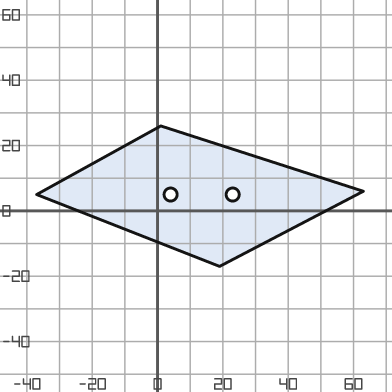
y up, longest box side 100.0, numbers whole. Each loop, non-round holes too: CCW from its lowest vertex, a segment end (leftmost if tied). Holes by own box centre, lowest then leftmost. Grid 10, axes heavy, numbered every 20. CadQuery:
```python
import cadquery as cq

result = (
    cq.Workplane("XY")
    .moveTo(19.0, -17.0)
    .lineTo(63.0, 6.0)
    .lineTo(1.0, 26.0)
    .lineTo(-37.0, 5.0)
    .close()
    .moveTo(4.0, 5.0)
    .circle(2.0)
    .moveTo(23.0, 5.0)
    .circle(2.0)
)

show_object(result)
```